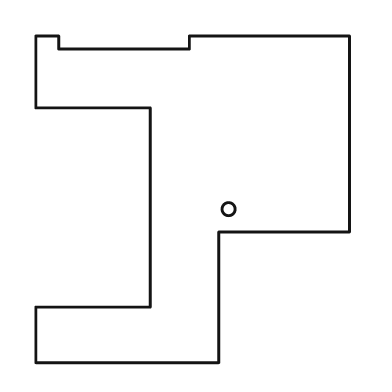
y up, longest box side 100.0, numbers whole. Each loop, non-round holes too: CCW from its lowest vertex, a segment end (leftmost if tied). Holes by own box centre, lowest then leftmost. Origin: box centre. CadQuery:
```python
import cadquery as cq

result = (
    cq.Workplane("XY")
    .moveTo(-48.0, -50.0)
    .lineTo(8.0, -50.0)
    .lineTo(8.0, -10.0)
    .lineTo(48.0, -10.0)
    .lineTo(48.0, 50.0)
    .lineTo(-1.0, 50.0)
    .lineTo(-1.0, 46.0)
    .lineTo(-41.0, 46.0)
    .lineTo(-41.0, 50.0)
    .lineTo(-48.0, 50.0)
    .lineTo(-48.0, 28.0)
    .lineTo(-13.0, 28.0)
    .lineTo(-13.0, -33.0)
    .lineTo(-48.0, -33.0)
    .close()
    .moveTo(11.0, -3.0)
    .circle(2.0)
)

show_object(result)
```